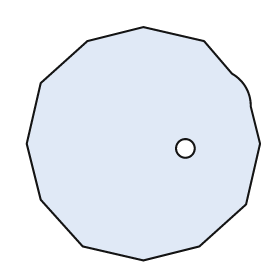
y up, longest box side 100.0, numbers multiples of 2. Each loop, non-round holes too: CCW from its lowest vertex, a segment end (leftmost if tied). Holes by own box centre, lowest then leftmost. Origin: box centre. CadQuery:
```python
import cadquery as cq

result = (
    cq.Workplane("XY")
    .moveTo(0.0, -50.0)
    .lineTo(24.0, -44.0)
    .lineTo(44.0, -26.0)
    .lineTo(50.0, 0.0)
    .lineTo(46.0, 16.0)
    .threePointArc((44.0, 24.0), (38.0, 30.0))
    .lineTo(26.0, 44.0)
    .lineTo(0.0, 50.0)
    .lineTo(-24.0, 44.0)
    .lineTo(-44.0, 26.0)
    .lineTo(-50.0, 0.0)
    .lineTo(-44.0, -24.0)
    .lineTo(-26.0, -44.0)
    .close()
    .moveTo(18.0, -2.0)
    .circle(4.0)
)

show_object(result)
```